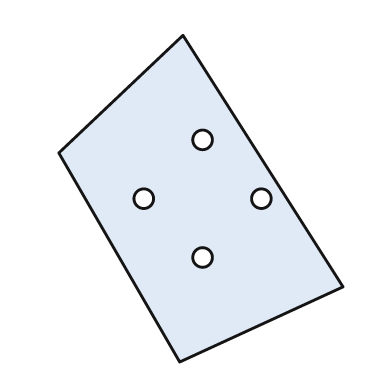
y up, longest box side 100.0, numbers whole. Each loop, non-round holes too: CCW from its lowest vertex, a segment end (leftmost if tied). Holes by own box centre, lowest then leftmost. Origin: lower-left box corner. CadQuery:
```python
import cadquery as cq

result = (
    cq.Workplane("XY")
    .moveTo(37.0, 0.0)
    .lineTo(87.0, 23.0)
    .lineTo(38.0, 100.0)
    .lineTo(0.0, 64.0)
    .close()
    .moveTo(44.0, 32.0)
    .circle(3.0)
    .moveTo(26.0, 50.0)
    .circle(3.0)
    .moveTo(62.0, 50.0)
    .circle(3.0)
    .moveTo(44.0, 68.0)
    .circle(3.0)
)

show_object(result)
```